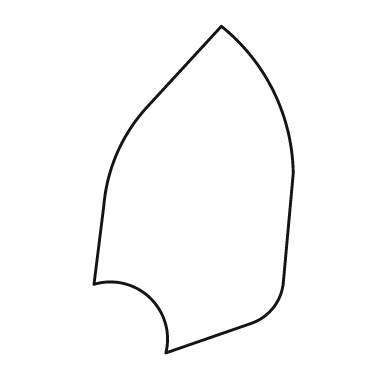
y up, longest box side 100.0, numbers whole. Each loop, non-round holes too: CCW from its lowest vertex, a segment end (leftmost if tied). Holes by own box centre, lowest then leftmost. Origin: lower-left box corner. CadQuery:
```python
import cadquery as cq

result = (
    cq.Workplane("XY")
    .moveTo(22.0, 0.0)
    .lineTo(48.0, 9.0)
    .threePointArc((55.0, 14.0), (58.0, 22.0))
    .lineTo(61.0, 55.0)
    .threePointArc((55.0, 80.0), (39.0, 100.0))
    .lineTo(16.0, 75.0)
    .threePointArc((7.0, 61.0), (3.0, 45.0))
    .lineTo(0.0, 21.0)
    .threePointArc((17.0, 17.0), (22.0, 0.0))
    .close()
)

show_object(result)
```